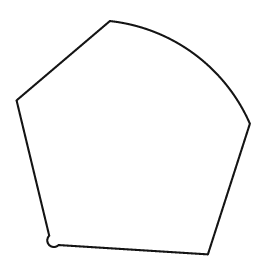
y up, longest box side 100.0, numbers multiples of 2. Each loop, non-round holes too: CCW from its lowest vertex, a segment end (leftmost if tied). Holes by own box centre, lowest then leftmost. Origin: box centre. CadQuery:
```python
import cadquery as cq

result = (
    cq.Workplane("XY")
    .moveTo(32.0, -50.0)
    .lineTo(50.0, 6.0)
    .threePointArc((26.0, 36.0), (-10.0, 50.0))
    .lineTo(-50.0, 16.0)
    .lineTo(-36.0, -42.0)
    .threePointArc((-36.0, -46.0), (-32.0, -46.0))
    .close()
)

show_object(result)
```